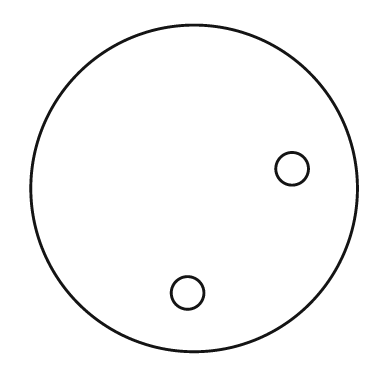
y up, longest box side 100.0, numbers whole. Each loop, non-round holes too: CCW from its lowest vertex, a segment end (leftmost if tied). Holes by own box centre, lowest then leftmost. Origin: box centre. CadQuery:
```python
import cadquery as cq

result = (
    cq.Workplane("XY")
    .moveTo(0.0, 0.0)
    .circle(50.0)
    .moveTo(-2.0, -32.0)
    .circle(5.0)
    .moveTo(30.0, 6.0)
    .circle(5.0)
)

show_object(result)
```